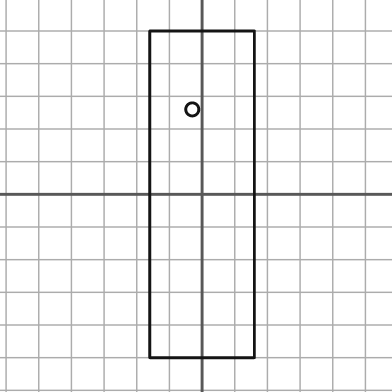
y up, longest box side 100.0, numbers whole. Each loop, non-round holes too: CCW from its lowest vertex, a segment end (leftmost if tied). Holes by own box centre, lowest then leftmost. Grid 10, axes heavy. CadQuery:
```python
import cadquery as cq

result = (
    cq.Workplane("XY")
    .moveTo(-16.0, -50.0)
    .lineTo(16.0, -50.0)
    .lineTo(16.0, 50.0)
    .lineTo(-16.0, 50.0)
    .close()
    .moveTo(-3.0, 26.0)
    .circle(2.0)
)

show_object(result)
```